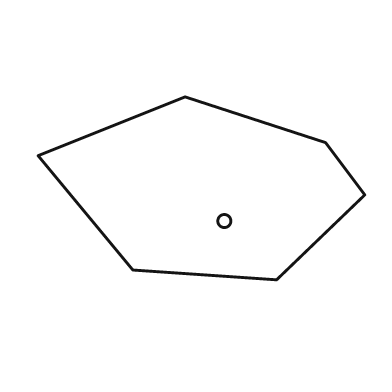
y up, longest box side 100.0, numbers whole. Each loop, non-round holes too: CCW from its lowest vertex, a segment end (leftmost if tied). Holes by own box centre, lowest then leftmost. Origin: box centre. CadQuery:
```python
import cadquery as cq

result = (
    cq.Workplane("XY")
    .moveTo(23.0, -28.0)
    .lineTo(50.0, -2.0)
    .lineTo(38.0, 14.0)
    .lineTo(-5.0, 28.0)
    .lineTo(-50.0, 10.0)
    .lineTo(-21.0, -25.0)
    .close()
    .moveTo(7.0, -10.0)
    .circle(2.0)
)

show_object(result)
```